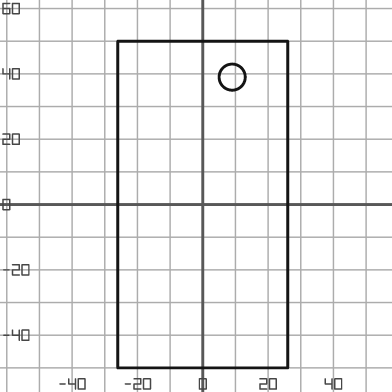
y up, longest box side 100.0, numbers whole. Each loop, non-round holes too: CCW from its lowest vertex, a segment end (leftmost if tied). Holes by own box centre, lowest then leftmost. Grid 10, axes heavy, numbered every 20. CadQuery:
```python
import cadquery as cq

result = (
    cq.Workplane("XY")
    .moveTo(-26.0, -50.0)
    .lineTo(26.0, -50.0)
    .lineTo(26.0, 50.0)
    .lineTo(-26.0, 50.0)
    .close()
    .moveTo(9.0, 39.0)
    .circle(4.0)
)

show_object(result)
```